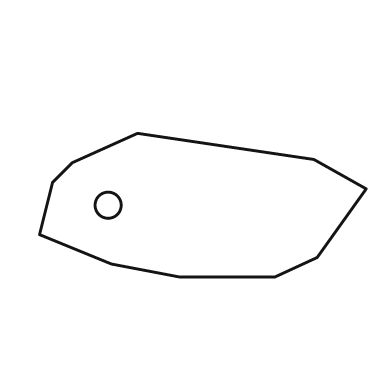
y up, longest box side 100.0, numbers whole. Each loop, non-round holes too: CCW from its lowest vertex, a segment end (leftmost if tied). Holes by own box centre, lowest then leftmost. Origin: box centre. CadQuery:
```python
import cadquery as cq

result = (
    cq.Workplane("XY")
    .moveTo(-7.0, -22.0)
    .lineTo(22.0, -22.0)
    .lineTo(35.0, -16.0)
    .lineTo(50.0, 5.0)
    .lineTo(34.0, 14.0)
    .lineTo(-20.0, 22.0)
    .lineTo(-40.0, 13.0)
    .lineTo(-46.0, 7.0)
    .lineTo(-50.0, -9.0)
    .lineTo(-28.0, -18.0)
    .close()
    .moveTo(-29.0, 0.0)
    .circle(4.0)
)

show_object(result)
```